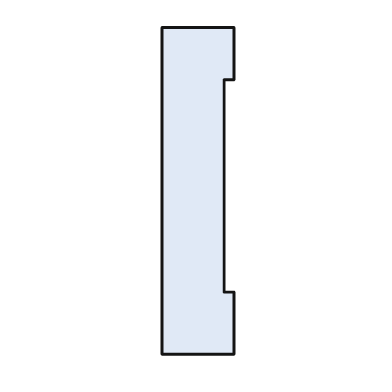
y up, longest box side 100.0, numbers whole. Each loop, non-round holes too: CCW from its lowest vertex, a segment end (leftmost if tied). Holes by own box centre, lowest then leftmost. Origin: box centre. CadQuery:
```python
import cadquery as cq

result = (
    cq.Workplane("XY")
    .moveTo(-11.0, -50.0)
    .lineTo(11.0, -50.0)
    .lineTo(11.0, -31.0)
    .lineTo(8.0, -31.0)
    .lineTo(8.0, 34.0)
    .lineTo(11.0, 34.0)
    .lineTo(11.0, 50.0)
    .lineTo(-11.0, 50.0)
    .close()
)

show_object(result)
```